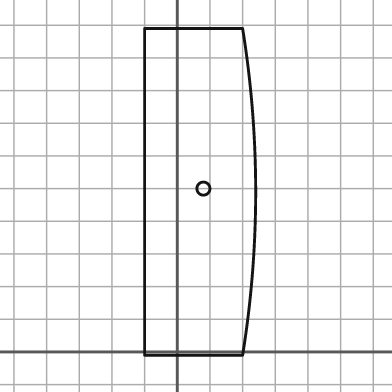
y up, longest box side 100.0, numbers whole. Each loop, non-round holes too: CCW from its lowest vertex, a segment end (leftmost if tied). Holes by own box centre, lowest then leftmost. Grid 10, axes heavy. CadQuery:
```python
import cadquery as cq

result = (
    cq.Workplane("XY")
    .moveTo(-10.0, -1.0)
    .lineTo(20.0, -1.0)
    .threePointArc((24.0, 49.0), (20.0, 99.0))
    .lineTo(-10.0, 99.0)
    .close()
    .moveTo(8.0, 50.0)
    .circle(2.0)
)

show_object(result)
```